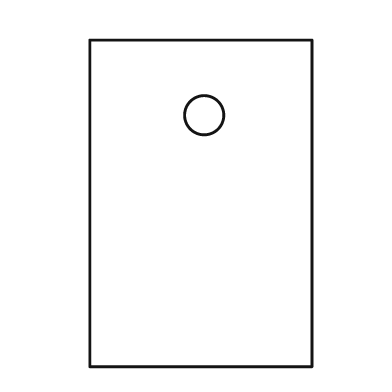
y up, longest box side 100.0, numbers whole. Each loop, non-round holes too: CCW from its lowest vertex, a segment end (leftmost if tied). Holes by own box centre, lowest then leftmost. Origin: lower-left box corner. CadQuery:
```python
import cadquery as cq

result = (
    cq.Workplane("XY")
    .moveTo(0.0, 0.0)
    .lineTo(68.0, 0.0)
    .lineTo(68.0, 100.0)
    .lineTo(0.0, 100.0)
    .close()
    .moveTo(35.0, 77.0)
    .circle(6.0)
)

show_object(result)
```